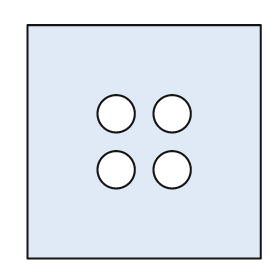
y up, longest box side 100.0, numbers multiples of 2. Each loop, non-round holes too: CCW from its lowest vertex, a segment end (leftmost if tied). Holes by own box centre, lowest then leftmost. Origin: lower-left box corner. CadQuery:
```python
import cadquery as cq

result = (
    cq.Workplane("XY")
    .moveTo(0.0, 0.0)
    .lineTo(100.0, 0.0)
    .lineTo(100.0, 100.0)
    .lineTo(0.0, 100.0)
    .close()
    .moveTo(38.0, 38.0)
    .circle(8.0)
    .moveTo(62.0, 38.0)
    .circle(8.0)
    .moveTo(38.0, 62.0)
    .circle(8.0)
    .moveTo(62.0, 62.0)
    .circle(8.0)
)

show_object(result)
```